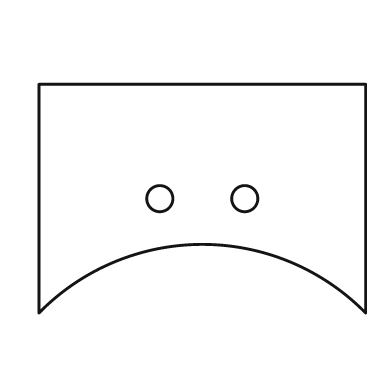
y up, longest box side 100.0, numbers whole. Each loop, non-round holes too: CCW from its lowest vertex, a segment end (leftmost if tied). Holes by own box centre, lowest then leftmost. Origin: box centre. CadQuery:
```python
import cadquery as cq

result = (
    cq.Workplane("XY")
    .moveTo(-50.0, -35.0)
    .threePointArc((0.0, -14.0), (50.0, -35.0))
    .lineTo(50.0, 35.0)
    .lineTo(-50.0, 35.0)
    .close()
    .moveTo(-13.0, 0.0)
    .circle(4.0)
    .moveTo(13.0, 0.0)
    .circle(4.0)
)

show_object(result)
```